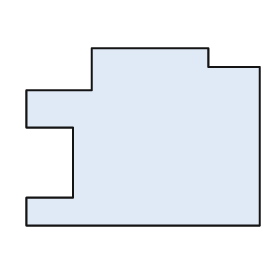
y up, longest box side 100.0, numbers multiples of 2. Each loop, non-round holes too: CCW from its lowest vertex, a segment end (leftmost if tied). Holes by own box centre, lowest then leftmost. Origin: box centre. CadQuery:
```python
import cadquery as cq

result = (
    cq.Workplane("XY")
    .moveTo(-50.0, -38.0)
    .lineTo(50.0, -38.0)
    .lineTo(50.0, 30.0)
    .lineTo(28.0, 30.0)
    .lineTo(28.0, 38.0)
    .lineTo(-22.0, 38.0)
    .lineTo(-22.0, 20.0)
    .lineTo(-50.0, 20.0)
    .lineTo(-50.0, 4.0)
    .lineTo(-30.0, 4.0)
    .lineTo(-30.0, -26.0)
    .lineTo(-50.0, -26.0)
    .close()
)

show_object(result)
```